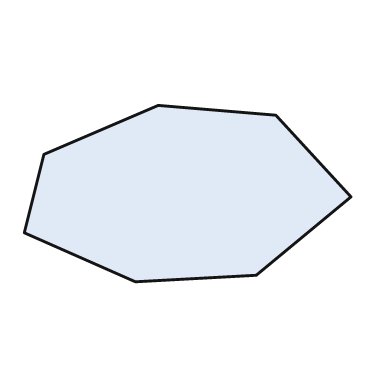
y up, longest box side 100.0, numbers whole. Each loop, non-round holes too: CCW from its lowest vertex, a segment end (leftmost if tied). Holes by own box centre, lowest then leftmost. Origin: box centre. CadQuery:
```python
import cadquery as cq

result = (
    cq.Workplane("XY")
    .moveTo(-16.0, -27.0)
    .lineTo(21.0, -25.0)
    .lineTo(50.0, -1.0)
    .lineTo(27.0, 24.0)
    .lineTo(-9.0, 27.0)
    .lineTo(-44.0, 12.0)
    .lineTo(-50.0, -12.0)
    .close()
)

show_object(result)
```